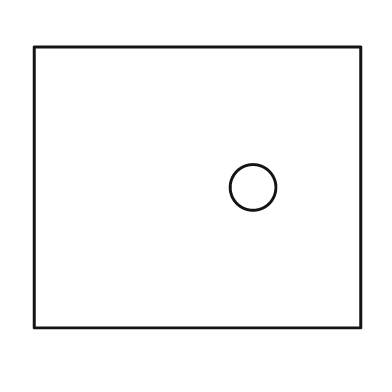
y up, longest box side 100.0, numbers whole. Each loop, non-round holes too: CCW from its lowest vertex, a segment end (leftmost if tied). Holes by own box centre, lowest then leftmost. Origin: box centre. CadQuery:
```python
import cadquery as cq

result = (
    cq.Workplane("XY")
    .moveTo(-50.0, -43.0)
    .lineTo(50.0, -43.0)
    .lineTo(50.0, 43.0)
    .lineTo(-50.0, 43.0)
    .close()
    .moveTo(17.0, 0.0)
    .circle(7.0)
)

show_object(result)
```